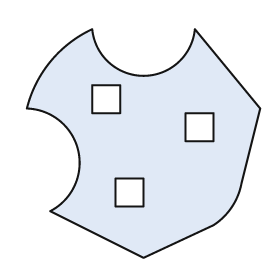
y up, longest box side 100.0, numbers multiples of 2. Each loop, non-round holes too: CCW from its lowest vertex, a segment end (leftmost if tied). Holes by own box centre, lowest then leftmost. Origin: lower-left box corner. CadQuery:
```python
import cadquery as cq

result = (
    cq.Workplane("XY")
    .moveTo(50.0, 0.0)
    .lineTo(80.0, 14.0)
    .threePointArc((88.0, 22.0), (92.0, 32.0))
    .lineTo(100.0, 64.0)
    .lineTo(72.0, 98.0)
    .threePointArc((50.0, 78.0), (28.0, 98.0))
    .threePointArc((10.0, 84.0), (0.0, 64.0))
    .threePointArc((22.0, 46.0), (10.0, 20.0))
    .close()
    .moveTo(38.0, 22.0)
    .lineTo(50.0, 22.0)
    .lineTo(50.0, 34.0)
    .lineTo(38.0, 34.0)
    .close()
    .moveTo(68.0, 50.0)
    .lineTo(80.0, 50.0)
    .lineTo(80.0, 62.0)
    .lineTo(68.0, 62.0)
    .close()
    .moveTo(28.0, 62.0)
    .lineTo(40.0, 62.0)
    .lineTo(40.0, 74.0)
    .lineTo(28.0, 74.0)
    .close()
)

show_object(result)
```